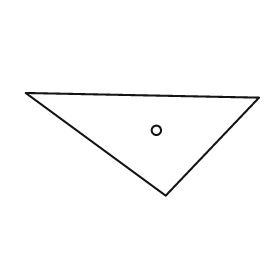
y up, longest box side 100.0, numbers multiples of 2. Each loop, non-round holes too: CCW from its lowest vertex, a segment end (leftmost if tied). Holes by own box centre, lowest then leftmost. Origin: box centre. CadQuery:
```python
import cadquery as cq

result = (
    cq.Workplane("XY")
    .moveTo(10.0, -22.0)
    .lineTo(50.0, 20.0)
    .lineTo(-50.0, 22.0)
    .close()
    .moveTo(6.0, 6.0)
    .circle(2.0)
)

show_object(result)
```